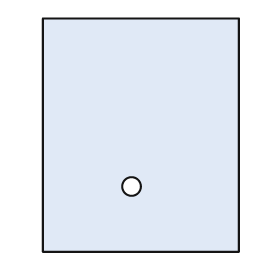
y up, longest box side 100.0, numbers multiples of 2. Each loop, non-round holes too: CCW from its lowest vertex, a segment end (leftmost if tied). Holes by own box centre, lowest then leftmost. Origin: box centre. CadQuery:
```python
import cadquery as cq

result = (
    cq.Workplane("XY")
    .moveTo(-42.0, -50.0)
    .lineTo(42.0, -50.0)
    .lineTo(42.0, 50.0)
    .lineTo(-42.0, 50.0)
    .close()
    .moveTo(-4.0, -22.0)
    .circle(4.0)
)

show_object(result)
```